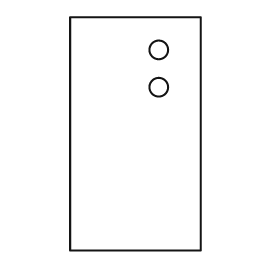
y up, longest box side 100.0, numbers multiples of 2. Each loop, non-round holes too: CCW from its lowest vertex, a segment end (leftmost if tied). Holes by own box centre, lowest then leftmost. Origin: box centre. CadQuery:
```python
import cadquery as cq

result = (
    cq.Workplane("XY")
    .moveTo(-28.0, -50.0)
    .lineTo(28.0, -50.0)
    .lineTo(28.0, 50.0)
    .lineTo(-28.0, 50.0)
    .close()
    .moveTo(10.0, 20.0)
    .circle(4.0)
    .moveTo(10.0, 36.0)
    .circle(4.0)
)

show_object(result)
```